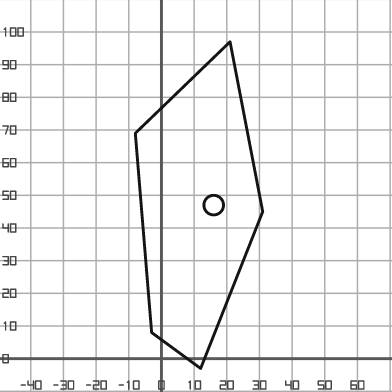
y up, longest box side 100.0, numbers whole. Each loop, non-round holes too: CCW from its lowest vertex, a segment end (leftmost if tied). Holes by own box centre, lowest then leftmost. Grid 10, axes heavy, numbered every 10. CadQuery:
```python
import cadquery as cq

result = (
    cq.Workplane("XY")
    .moveTo(12.0, -3.0)
    .lineTo(31.0, 45.0)
    .lineTo(21.0, 97.0)
    .lineTo(-8.0, 69.0)
    .lineTo(-3.0, 8.0)
    .close()
    .moveTo(16.0, 47.0)
    .circle(3.0)
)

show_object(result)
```